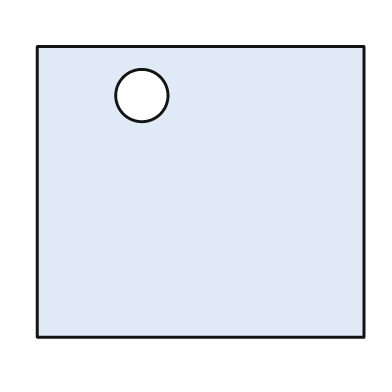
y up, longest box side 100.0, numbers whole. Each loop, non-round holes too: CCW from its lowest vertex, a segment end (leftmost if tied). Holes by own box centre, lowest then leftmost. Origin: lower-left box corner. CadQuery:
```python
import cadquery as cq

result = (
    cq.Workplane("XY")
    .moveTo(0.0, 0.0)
    .lineTo(100.0, 0.0)
    .lineTo(100.0, 89.0)
    .lineTo(0.0, 89.0)
    .close()
    .moveTo(32.0, 74.0)
    .circle(8.0)
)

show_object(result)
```